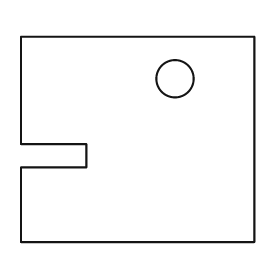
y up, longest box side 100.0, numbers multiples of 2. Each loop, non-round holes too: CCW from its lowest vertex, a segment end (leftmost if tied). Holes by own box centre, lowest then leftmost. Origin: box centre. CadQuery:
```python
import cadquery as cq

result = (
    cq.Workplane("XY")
    .moveTo(-50.0, -44.0)
    .lineTo(50.0, -44.0)
    .lineTo(50.0, 44.0)
    .lineTo(-50.0, 44.0)
    .lineTo(-50.0, -2.0)
    .lineTo(-22.0, -2.0)
    .lineTo(-22.0, -12.0)
    .lineTo(-50.0, -12.0)
    .close()
    .moveTo(16.0, 26.0)
    .circle(8.0)
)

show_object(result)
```